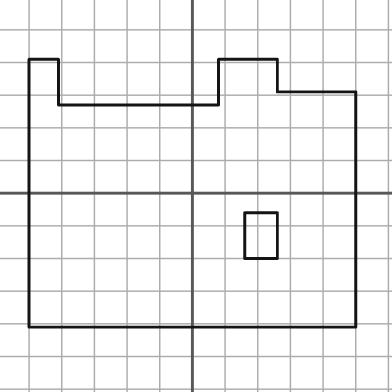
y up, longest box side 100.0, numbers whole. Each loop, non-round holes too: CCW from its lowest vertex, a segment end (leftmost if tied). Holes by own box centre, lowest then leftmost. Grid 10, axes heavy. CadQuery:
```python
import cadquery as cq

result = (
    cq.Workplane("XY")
    .moveTo(-50.0, -41.0)
    .lineTo(50.0, -41.0)
    .lineTo(50.0, 31.0)
    .lineTo(26.0, 31.0)
    .lineTo(26.0, 41.0)
    .lineTo(8.0, 41.0)
    .lineTo(8.0, 27.0)
    .lineTo(-41.0, 27.0)
    .lineTo(-41.0, 41.0)
    .lineTo(-50.0, 41.0)
    .close()
    .moveTo(16.0, -20.0)
    .lineTo(26.0, -20.0)
    .lineTo(26.0, -6.0)
    .lineTo(16.0, -6.0)
    .close()
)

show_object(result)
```